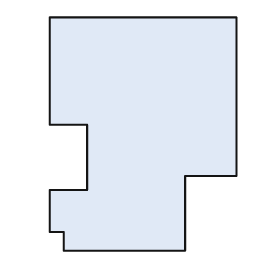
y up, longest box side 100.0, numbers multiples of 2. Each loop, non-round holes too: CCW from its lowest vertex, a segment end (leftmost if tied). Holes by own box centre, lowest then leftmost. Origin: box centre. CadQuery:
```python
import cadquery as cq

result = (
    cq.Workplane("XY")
    .moveTo(-34.0, -50.0)
    .lineTo(18.0, -50.0)
    .lineTo(18.0, -18.0)
    .lineTo(40.0, -18.0)
    .lineTo(40.0, 50.0)
    .lineTo(-40.0, 50.0)
    .lineTo(-40.0, 4.0)
    .lineTo(-24.0, 4.0)
    .lineTo(-24.0, -24.0)
    .lineTo(-40.0, -24.0)
    .lineTo(-40.0, -42.0)
    .lineTo(-34.0, -42.0)
    .close()
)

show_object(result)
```